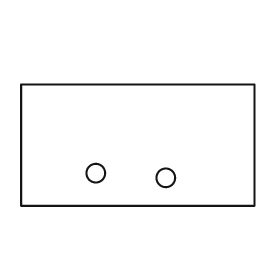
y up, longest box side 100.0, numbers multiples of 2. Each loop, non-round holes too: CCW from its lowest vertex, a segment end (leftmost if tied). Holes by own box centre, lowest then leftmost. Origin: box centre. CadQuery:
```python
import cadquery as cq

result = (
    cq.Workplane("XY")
    .moveTo(-50.0, -26.0)
    .lineTo(50.0, -26.0)
    .lineTo(50.0, 26.0)
    .lineTo(-50.0, 26.0)
    .close()
    .moveTo(12.0, -14.0)
    .circle(4.0)
    .moveTo(-18.0, -12.0)
    .circle(4.0)
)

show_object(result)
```